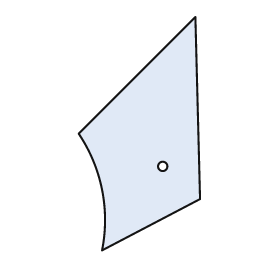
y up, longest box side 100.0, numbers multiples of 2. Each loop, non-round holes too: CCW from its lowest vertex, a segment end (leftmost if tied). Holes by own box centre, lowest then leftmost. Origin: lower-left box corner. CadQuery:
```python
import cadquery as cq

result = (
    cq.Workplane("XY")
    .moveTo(10.0, 0.0)
    .lineTo(52.0, 22.0)
    .lineTo(50.0, 100.0)
    .lineTo(0.0, 50.0)
    .threePointArc((10.0, 26.0), (10.0, 0.0))
    .close()
    .moveTo(36.0, 36.0)
    .circle(2.0)
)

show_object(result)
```